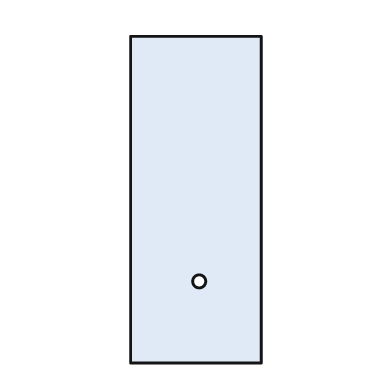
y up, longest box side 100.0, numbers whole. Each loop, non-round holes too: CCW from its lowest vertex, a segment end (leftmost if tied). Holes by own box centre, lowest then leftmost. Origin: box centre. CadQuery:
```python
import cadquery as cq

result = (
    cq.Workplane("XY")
    .moveTo(-20.0, -50.0)
    .lineTo(20.0, -50.0)
    .lineTo(20.0, 50.0)
    .lineTo(-20.0, 50.0)
    .close()
    .moveTo(1.0, -25.0)
    .circle(2.0)
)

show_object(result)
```